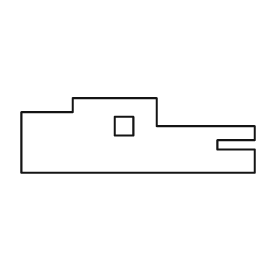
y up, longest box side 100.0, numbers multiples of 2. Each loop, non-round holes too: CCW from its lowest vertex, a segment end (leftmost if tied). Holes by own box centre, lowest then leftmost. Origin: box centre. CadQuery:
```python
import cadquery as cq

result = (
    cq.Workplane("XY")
    .moveTo(-50.0, -16.0)
    .lineTo(50.0, -16.0)
    .lineTo(50.0, -6.0)
    .lineTo(34.0, -6.0)
    .lineTo(34.0, -2.0)
    .lineTo(50.0, -2.0)
    .lineTo(50.0, 4.0)
    .lineTo(8.0, 4.0)
    .lineTo(8.0, 16.0)
    .lineTo(-28.0, 16.0)
    .lineTo(-28.0, 10.0)
    .lineTo(-50.0, 10.0)
    .close()
    .moveTo(-10.0, 0.0)
    .lineTo(-2.0, 0.0)
    .lineTo(-2.0, 8.0)
    .lineTo(-10.0, 8.0)
    .close()
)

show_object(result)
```